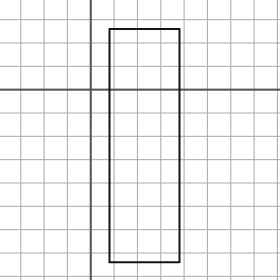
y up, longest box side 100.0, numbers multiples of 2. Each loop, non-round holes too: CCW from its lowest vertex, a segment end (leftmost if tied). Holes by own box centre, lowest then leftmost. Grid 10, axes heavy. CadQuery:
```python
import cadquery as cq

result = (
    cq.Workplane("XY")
    .moveTo(8.0, -74.0)
    .lineTo(38.0, -74.0)
    .lineTo(38.0, 26.0)
    .lineTo(8.0, 26.0)
    .close()
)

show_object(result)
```